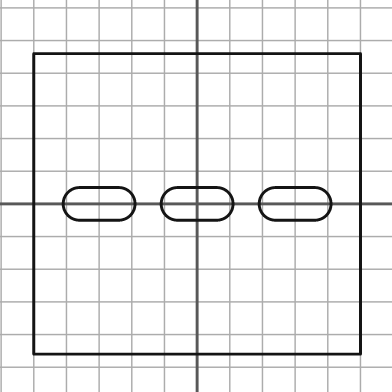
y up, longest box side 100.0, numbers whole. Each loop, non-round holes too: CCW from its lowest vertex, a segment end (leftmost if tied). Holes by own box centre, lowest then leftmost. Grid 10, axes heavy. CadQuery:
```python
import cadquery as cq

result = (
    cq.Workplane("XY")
    .moveTo(-50.0, -46.0)
    .lineTo(50.0, -46.0)
    .lineTo(50.0, 46.0)
    .lineTo(-50.0, 46.0)
    .close()
    .moveTo(-36.0, -5.0)
    .lineTo(-24.0, -5.0)
    .threePointArc((-19.0, 0.0), (-24.0, 5.0))
    .lineTo(-36.0, 5.0)
    .threePointArc((-41.0, 0.0), (-36.0, -5.0))
    .close()
    .moveTo(-6.0, -5.0)
    .lineTo(6.0, -5.0)
    .threePointArc((11.0, 0.0), (6.0, 5.0))
    .lineTo(-6.0, 5.0)
    .threePointArc((-11.0, 0.0), (-6.0, -5.0))
    .close()
    .moveTo(24.0, -5.0)
    .lineTo(36.0, -5.0)
    .threePointArc((41.0, 0.0), (36.0, 5.0))
    .lineTo(24.0, 5.0)
    .threePointArc((19.0, 0.0), (24.0, -5.0))
    .close()
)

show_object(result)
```